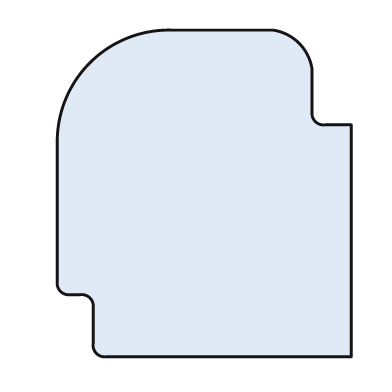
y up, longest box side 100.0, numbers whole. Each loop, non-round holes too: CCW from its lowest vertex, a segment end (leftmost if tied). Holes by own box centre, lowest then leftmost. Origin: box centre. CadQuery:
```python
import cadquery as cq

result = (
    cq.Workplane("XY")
    .moveTo(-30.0, -50.0)
    .lineTo(45.0, -50.0)
    .lineTo(45.0, 21.0)
    .lineTo(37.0, 21.0)
    .threePointArc((34.0, 22.0), (33.0, 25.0))
    .lineTo(33.0, 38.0)
    .threePointArc((29.0, 46.0), (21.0, 50.0))
    .lineTo(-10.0, 50.0)
    .threePointArc((-35.0, 40.0), (-45.0, 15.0))
    .lineTo(-45.0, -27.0)
    .threePointArc((-44.0, -30.0), (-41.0, -31.0))
    .lineTo(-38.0, -31.0)
    .threePointArc((-35.0, -32.0), (-34.0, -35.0))
    .lineTo(-34.0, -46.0)
    .threePointArc((-33.0, -49.0), (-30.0, -50.0))
    .close()
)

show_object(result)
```